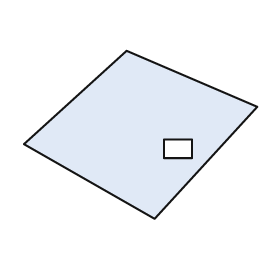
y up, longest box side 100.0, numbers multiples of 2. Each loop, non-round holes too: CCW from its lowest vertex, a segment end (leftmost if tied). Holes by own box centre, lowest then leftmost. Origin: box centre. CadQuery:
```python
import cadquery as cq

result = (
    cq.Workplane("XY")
    .moveTo(6.0, -36.0)
    .lineTo(50.0, 12.0)
    .lineTo(-6.0, 36.0)
    .lineTo(-50.0, -4.0)
    .close()
    .moveTo(10.0, -10.0)
    .lineTo(22.0, -10.0)
    .lineTo(22.0, -2.0)
    .lineTo(10.0, -2.0)
    .close()
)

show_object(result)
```